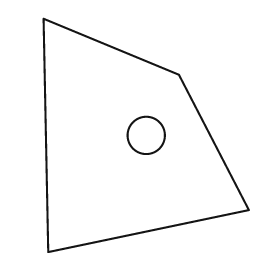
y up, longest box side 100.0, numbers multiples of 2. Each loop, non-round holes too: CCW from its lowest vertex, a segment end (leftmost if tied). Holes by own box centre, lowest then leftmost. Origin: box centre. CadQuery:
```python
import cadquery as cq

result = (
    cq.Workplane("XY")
    .moveTo(-42.0, -50.0)
    .lineTo(44.0, -32.0)
    .lineTo(14.0, 26.0)
    .lineTo(-44.0, 50.0)
    .close()
    .moveTo(0.0, 0.0)
    .circle(8.0)
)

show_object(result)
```